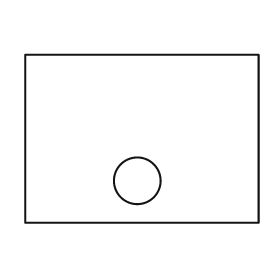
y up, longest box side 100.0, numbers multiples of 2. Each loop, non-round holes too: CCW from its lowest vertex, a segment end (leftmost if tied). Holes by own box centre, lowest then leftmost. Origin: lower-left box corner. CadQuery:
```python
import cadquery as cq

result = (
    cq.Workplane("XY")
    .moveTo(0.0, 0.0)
    .lineTo(100.0, 0.0)
    .lineTo(100.0, 72.0)
    .lineTo(0.0, 72.0)
    .close()
    .moveTo(48.0, 18.0)
    .circle(10.0)
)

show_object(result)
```